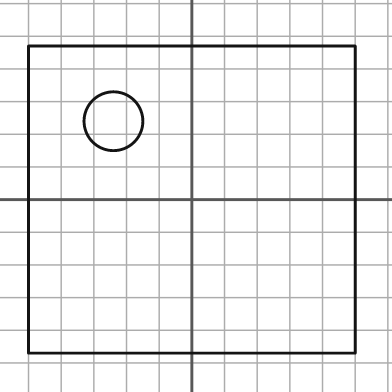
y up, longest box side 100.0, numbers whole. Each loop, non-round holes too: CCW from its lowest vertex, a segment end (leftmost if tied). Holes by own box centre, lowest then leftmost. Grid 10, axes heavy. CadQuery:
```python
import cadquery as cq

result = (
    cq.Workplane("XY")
    .moveTo(-50.0, -47.0)
    .lineTo(50.0, -47.0)
    .lineTo(50.0, 47.0)
    .lineTo(-50.0, 47.0)
    .close()
    .moveTo(-24.0, 24.0)
    .circle(9.0)
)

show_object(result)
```